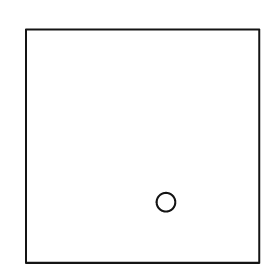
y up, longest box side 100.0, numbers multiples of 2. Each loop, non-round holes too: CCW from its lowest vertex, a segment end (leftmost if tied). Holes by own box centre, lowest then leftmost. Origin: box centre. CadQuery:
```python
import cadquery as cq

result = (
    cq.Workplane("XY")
    .moveTo(-50.0, -50.0)
    .lineTo(50.0, -50.0)
    .lineTo(50.0, 50.0)
    .lineTo(-50.0, 50.0)
    .close()
    .moveTo(10.0, -24.0)
    .circle(4.0)
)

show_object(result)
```